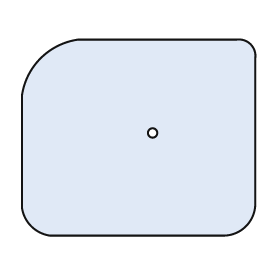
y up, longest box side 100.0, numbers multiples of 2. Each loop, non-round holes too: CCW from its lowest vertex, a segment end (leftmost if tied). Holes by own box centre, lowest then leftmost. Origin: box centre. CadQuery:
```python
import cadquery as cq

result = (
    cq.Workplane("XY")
    .moveTo(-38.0, -42.0)
    .lineTo(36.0, -42.0)
    .threePointArc((46.0, -38.0), (50.0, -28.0))
    .lineTo(50.0, 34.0)
    .threePointArc((48.0, 40.0), (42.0, 42.0))
    .lineTo(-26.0, 42.0)
    .threePointArc((-42.0, 34.0), (-50.0, 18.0))
    .lineTo(-50.0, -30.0)
    .threePointArc((-46.0, -38.0), (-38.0, -42.0))
    .close()
    .moveTo(6.0, 2.0)
    .circle(2.0)
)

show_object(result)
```